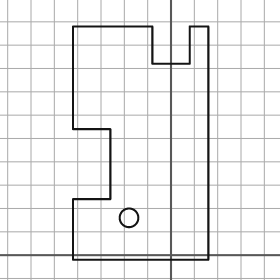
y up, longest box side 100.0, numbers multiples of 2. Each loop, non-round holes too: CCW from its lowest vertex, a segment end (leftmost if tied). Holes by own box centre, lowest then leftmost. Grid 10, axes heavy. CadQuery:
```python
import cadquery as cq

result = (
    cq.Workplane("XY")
    .moveTo(-42.0, -2.0)
    .lineTo(16.0, -2.0)
    .lineTo(16.0, 98.0)
    .lineTo(8.0, 98.0)
    .lineTo(8.0, 82.0)
    .lineTo(-8.0, 82.0)
    .lineTo(-8.0, 98.0)
    .lineTo(-42.0, 98.0)
    .lineTo(-42.0, 54.0)
    .lineTo(-26.0, 54.0)
    .lineTo(-26.0, 24.0)
    .lineTo(-42.0, 24.0)
    .close()
    .moveTo(-18.0, 16.0)
    .circle(4.0)
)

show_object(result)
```